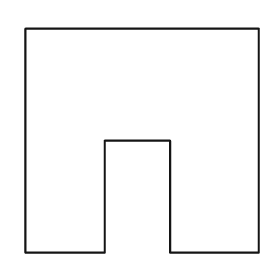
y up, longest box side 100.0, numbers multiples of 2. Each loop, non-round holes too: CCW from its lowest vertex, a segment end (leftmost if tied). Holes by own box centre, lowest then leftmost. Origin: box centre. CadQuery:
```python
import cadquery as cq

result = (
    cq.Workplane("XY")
    .moveTo(-50.0, -48.0)
    .lineTo(-16.0, -48.0)
    .lineTo(-16.0, 0.0)
    .lineTo(12.0, 0.0)
    .lineTo(12.0, -48.0)
    .lineTo(50.0, -48.0)
    .lineTo(50.0, 48.0)
    .lineTo(-50.0, 48.0)
    .close()
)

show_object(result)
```